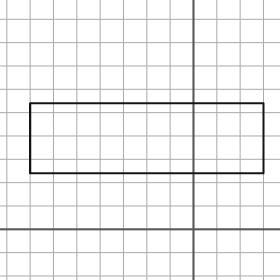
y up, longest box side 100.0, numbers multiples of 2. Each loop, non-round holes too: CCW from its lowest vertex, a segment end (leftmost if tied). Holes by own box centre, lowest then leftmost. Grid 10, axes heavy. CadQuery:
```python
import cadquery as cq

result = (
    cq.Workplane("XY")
    .moveTo(-70.0, 24.0)
    .lineTo(30.0, 24.0)
    .lineTo(30.0, 54.0)
    .lineTo(-70.0, 54.0)
    .close()
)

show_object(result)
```